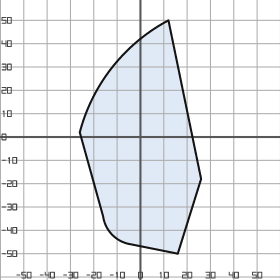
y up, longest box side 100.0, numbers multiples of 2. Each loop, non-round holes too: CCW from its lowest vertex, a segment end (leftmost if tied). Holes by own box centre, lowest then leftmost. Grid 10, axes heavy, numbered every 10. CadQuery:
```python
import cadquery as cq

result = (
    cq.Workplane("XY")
    .moveTo(16.0, -50.0)
    .lineTo(26.0, -18.0)
    .lineTo(12.0, 50.0)
    .threePointArc((-12.0, 30.0), (-26.0, 2.0))
    .lineTo(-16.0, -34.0)
    .threePointArc((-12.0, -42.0), (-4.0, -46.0))
    .close()
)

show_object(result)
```